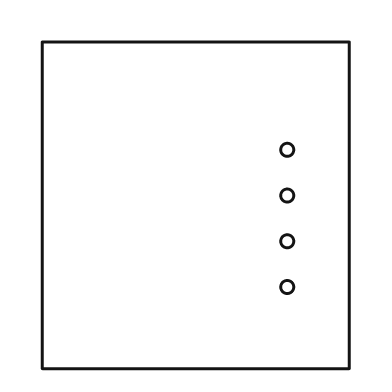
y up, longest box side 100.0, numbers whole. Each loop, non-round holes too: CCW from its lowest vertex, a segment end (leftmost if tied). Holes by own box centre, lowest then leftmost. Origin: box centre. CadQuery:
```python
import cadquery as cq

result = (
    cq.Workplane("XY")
    .moveTo(-47.0, -50.0)
    .lineTo(47.0, -50.0)
    .lineTo(47.0, 50.0)
    .lineTo(-47.0, 50.0)
    .close()
    .moveTo(28.0, -25.0)
    .circle(2.0)
    .moveTo(28.0, -11.0)
    .circle(2.0)
    .moveTo(28.0, 3.0)
    .circle(2.0)
    .moveTo(28.0, 17.0)
    .circle(2.0)
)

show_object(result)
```